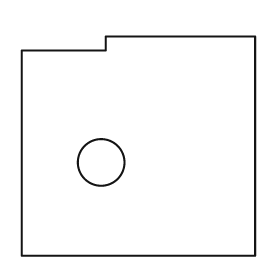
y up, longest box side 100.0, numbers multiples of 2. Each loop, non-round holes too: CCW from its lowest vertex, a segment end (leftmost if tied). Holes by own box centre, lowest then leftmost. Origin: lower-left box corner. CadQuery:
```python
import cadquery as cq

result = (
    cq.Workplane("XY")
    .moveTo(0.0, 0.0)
    .lineTo(100.0, 0.0)
    .lineTo(100.0, 94.0)
    .lineTo(36.0, 94.0)
    .lineTo(36.0, 88.0)
    .lineTo(0.0, 88.0)
    .close()
    .moveTo(34.0, 40.0)
    .circle(10.0)
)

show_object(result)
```